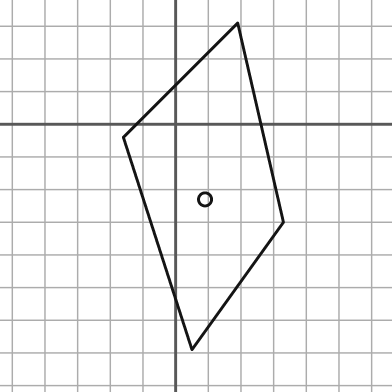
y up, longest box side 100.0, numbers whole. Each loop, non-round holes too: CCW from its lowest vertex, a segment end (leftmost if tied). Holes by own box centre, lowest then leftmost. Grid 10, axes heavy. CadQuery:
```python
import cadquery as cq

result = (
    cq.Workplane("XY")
    .moveTo(5.0, -69.0)
    .lineTo(33.0, -30.0)
    .lineTo(19.0, 31.0)
    .lineTo(-16.0, -4.0)
    .close()
    .moveTo(9.0, -23.0)
    .circle(2.0)
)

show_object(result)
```